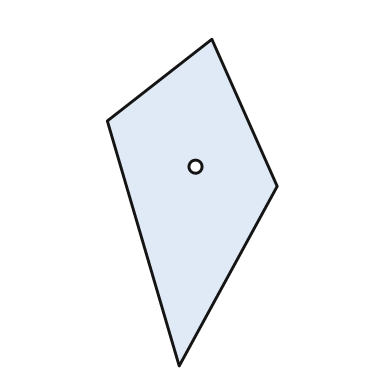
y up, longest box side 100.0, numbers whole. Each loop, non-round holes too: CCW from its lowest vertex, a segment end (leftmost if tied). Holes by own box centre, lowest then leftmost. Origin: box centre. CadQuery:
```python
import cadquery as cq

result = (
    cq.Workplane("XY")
    .moveTo(-4.0, -50.0)
    .lineTo(26.0, 5.0)
    .lineTo(6.0, 50.0)
    .lineTo(-26.0, 25.0)
    .close()
    .moveTo(1.0, 11.0)
    .circle(2.0)
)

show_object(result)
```